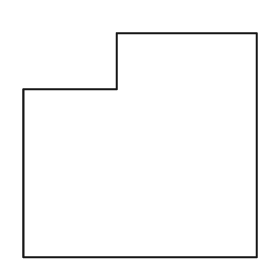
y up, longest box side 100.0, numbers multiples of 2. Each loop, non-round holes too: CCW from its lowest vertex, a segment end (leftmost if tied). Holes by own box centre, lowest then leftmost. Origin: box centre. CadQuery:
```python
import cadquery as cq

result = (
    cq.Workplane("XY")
    .moveTo(-50.0, -48.0)
    .lineTo(50.0, -48.0)
    .lineTo(50.0, 48.0)
    .lineTo(-10.0, 48.0)
    .lineTo(-10.0, 24.0)
    .lineTo(-50.0, 24.0)
    .close()
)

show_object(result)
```